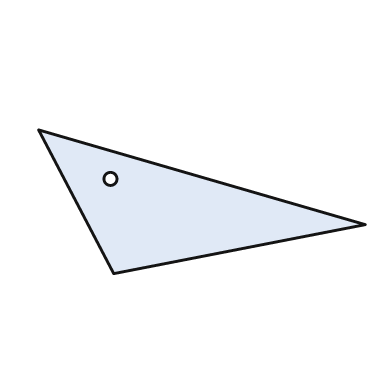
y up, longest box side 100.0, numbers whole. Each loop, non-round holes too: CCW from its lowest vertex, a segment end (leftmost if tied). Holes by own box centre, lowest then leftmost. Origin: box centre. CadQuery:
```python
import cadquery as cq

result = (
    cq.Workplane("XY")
    .moveTo(-27.0, -22.0)
    .lineTo(50.0, -7.0)
    .lineTo(-50.0, 22.0)
    .close()
    .moveTo(-28.0, 7.0)
    .circle(2.0)
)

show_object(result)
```